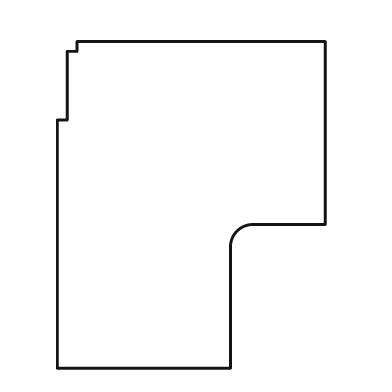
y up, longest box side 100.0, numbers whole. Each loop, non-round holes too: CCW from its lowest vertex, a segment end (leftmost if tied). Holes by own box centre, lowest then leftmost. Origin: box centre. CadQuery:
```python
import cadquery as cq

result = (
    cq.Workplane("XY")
    .moveTo(-41.0, -50.0)
    .lineTo(12.0, -50.0)
    .lineTo(12.0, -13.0)
    .threePointArc((14.0, -8.0), (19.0, -6.0))
    .lineTo(41.0, -6.0)
    .lineTo(41.0, 50.0)
    .lineTo(-35.0, 50.0)
    .lineTo(-35.0, 47.0)
    .lineTo(-38.0, 47.0)
    .lineTo(-38.0, 26.0)
    .lineTo(-41.0, 26.0)
    .close()
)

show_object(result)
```